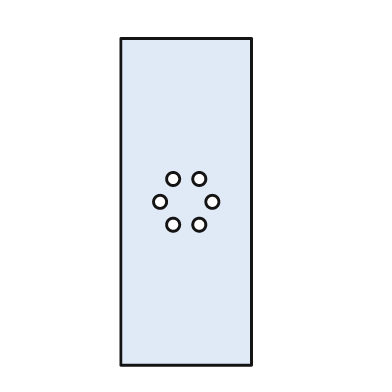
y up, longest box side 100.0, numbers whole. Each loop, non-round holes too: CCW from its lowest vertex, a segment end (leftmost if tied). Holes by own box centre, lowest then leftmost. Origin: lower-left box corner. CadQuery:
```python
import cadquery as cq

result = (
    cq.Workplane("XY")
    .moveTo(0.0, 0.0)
    .lineTo(40.0, 0.0)
    .lineTo(40.0, 100.0)
    .lineTo(0.0, 100.0)
    .close()
    .moveTo(16.0, 43.0)
    .circle(2.0)
    .moveTo(24.0, 43.0)
    .circle(2.0)
    .moveTo(12.0, 50.0)
    .circle(2.0)
    .moveTo(28.0, 50.0)
    .circle(2.0)
    .moveTo(16.0, 57.0)
    .circle(2.0)
    .moveTo(24.0, 57.0)
    .circle(2.0)
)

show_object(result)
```